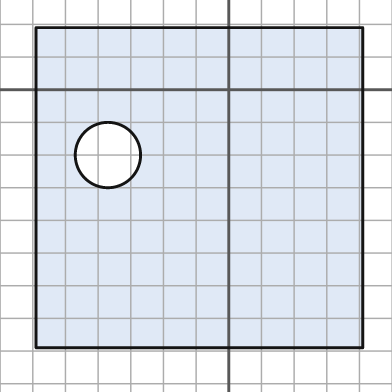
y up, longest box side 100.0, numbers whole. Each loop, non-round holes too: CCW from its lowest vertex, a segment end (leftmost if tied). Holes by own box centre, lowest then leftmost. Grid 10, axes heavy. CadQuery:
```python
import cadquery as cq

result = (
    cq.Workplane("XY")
    .moveTo(-59.0, -79.0)
    .lineTo(41.0, -79.0)
    .lineTo(41.0, 19.0)
    .lineTo(-59.0, 19.0)
    .close()
    .moveTo(-37.0, -20.0)
    .circle(10.0)
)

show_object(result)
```